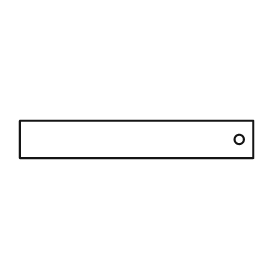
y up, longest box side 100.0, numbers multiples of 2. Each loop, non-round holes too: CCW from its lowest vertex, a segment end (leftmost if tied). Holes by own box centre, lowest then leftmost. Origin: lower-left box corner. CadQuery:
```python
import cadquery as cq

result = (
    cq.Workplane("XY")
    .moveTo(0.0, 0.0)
    .lineTo(100.0, 0.0)
    .lineTo(100.0, 16.0)
    .lineTo(0.0, 16.0)
    .close()
    .moveTo(94.0, 8.0)
    .circle(2.0)
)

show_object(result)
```